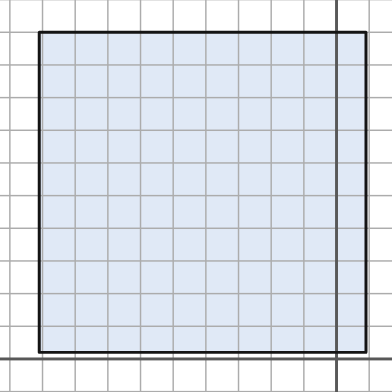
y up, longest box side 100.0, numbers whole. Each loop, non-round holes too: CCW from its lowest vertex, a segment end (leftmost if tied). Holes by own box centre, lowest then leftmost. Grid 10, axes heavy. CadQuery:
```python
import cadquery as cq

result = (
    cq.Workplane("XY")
    .moveTo(-91.0, 2.0)
    .lineTo(9.0, 2.0)
    .lineTo(9.0, 100.0)
    .lineTo(-91.0, 100.0)
    .close()
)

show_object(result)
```